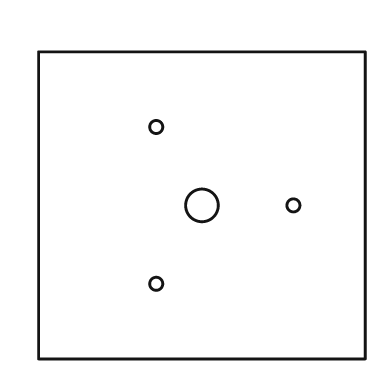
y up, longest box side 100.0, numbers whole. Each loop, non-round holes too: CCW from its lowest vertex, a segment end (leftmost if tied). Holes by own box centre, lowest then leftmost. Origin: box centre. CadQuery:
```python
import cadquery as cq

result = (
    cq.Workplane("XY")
    .moveTo(-50.0, -47.0)
    .lineTo(50.0, -47.0)
    .lineTo(50.0, 47.0)
    .lineTo(-50.0, 47.0)
    .close()
    .moveTo(-14.0, -24.0)
    .circle(2.0)
    .moveTo(0.0, 0.0)
    .circle(5.0)
    .moveTo(28.0, 0.0)
    .circle(2.0)
    .moveTo(-14.0, 24.0)
    .circle(2.0)
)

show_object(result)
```